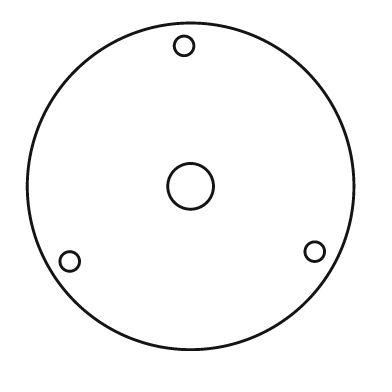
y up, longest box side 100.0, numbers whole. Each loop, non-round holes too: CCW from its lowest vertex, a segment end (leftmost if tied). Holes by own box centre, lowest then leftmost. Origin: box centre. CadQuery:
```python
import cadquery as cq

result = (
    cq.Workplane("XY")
    .moveTo(0.0, 0.0)
    .circle(50.0)
    .moveTo(-37.0, -23.0)
    .circle(3.0)
    .moveTo(38.0, -20.0)
    .circle(3.0)
    .moveTo(0.0, 0.0)
    .circle(7.0)
    .moveTo(-2.0, 43.0)
    .circle(3.0)
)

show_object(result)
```